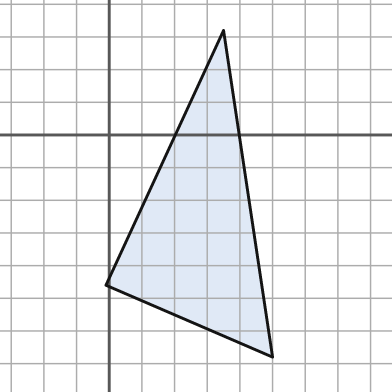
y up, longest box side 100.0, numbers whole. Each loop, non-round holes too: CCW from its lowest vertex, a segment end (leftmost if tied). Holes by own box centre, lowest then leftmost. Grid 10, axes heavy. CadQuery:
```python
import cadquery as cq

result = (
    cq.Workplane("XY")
    .moveTo(50.0, -68.0)
    .lineTo(35.0, 32.0)
    .lineTo(-1.0, -46.0)
    .close()
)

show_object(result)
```